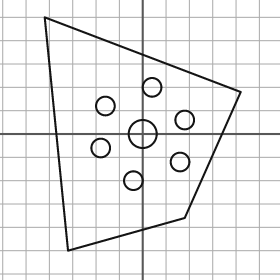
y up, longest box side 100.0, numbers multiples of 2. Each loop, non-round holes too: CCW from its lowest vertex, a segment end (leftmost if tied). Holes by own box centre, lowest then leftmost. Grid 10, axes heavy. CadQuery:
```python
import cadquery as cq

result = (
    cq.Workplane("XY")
    .moveTo(-32.0, -50.0)
    .lineTo(18.0, -36.0)
    .lineTo(42.0, 18.0)
    .lineTo(-42.0, 50.0)
    .close()
    .moveTo(-4.0, -20.0)
    .circle(4.0)
    .moveTo(16.0, -12.0)
    .circle(4.0)
    .moveTo(-18.0, -6.0)
    .circle(4.0)
    .moveTo(0.0, 0.0)
    .circle(6.0)
    .moveTo(18.0, 6.0)
    .circle(4.0)
    .moveTo(-16.0, 12.0)
    .circle(4.0)
    .moveTo(4.0, 20.0)
    .circle(4.0)
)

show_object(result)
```